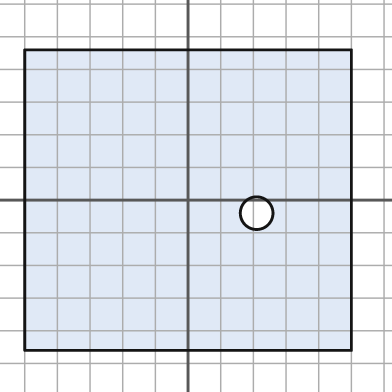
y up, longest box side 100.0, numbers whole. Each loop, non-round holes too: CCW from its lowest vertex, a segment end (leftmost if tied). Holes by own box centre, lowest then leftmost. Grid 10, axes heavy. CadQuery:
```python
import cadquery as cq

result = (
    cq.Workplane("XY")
    .moveTo(-50.0, -46.0)
    .lineTo(50.0, -46.0)
    .lineTo(50.0, 46.0)
    .lineTo(-50.0, 46.0)
    .close()
    .moveTo(21.0, -4.0)
    .circle(5.0)
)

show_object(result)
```